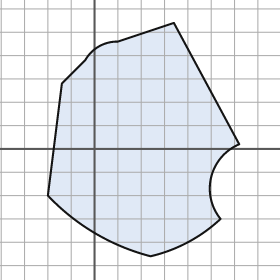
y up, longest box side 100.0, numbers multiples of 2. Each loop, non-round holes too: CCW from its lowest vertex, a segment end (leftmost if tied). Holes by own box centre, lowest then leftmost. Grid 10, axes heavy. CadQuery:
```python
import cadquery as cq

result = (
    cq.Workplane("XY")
    .moveTo(24.0, -46.0)
    .threePointArc((40.0, -40.0), (54.0, -30.0))
    .threePointArc((50.0, -12.0), (62.0, 2.0))
    .lineTo(34.0, 54.0)
    .lineTo(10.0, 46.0)
    .threePointArc((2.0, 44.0), (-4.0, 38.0))
    .lineTo(-14.0, 28.0)
    .lineTo(-20.0, -20.0)
    .threePointArc((0.0, -36.0), (24.0, -46.0))
    .close()
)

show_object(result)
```